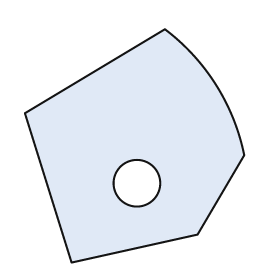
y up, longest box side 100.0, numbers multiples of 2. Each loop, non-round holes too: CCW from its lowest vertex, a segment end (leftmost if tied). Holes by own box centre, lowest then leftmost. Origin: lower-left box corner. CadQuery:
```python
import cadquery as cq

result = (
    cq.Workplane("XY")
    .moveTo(20.0, 0.0)
    .lineTo(74.0, 12.0)
    .lineTo(94.0, 46.0)
    .threePointArc((82.0, 76.0), (60.0, 100.0))
    .lineTo(0.0, 64.0)
    .close()
    .moveTo(48.0, 34.0)
    .circle(10.0)
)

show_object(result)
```